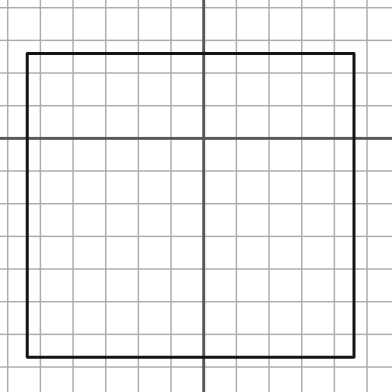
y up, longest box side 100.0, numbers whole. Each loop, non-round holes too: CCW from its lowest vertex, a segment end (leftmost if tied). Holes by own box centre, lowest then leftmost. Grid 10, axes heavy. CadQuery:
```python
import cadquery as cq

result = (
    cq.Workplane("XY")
    .moveTo(-54.0, -67.0)
    .lineTo(46.0, -67.0)
    .lineTo(46.0, 26.0)
    .lineTo(-54.0, 26.0)
    .close()
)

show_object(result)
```